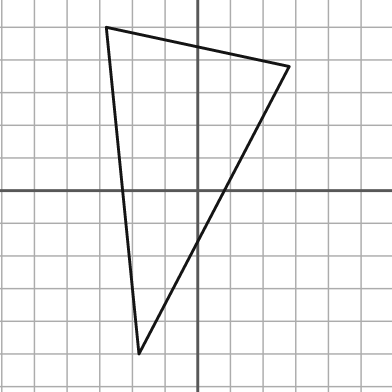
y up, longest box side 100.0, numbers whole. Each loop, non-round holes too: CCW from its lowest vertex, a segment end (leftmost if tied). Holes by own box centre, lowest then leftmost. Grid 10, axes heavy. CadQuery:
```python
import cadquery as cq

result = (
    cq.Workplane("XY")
    .moveTo(-18.0, -50.0)
    .lineTo(28.0, 38.0)
    .lineTo(-28.0, 50.0)
    .close()
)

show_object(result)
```